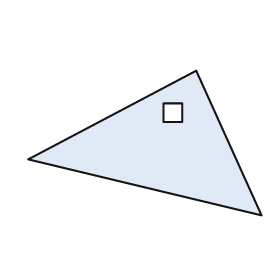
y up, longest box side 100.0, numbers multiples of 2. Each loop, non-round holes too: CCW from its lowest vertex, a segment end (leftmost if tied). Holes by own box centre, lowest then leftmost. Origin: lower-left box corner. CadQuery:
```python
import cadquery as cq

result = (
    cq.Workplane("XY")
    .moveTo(100.0, 0.0)
    .lineTo(72.0, 62.0)
    .lineTo(0.0, 24.0)
    .close()
    .moveTo(58.0, 40.0)
    .lineTo(66.0, 40.0)
    .lineTo(66.0, 48.0)
    .lineTo(58.0, 48.0)
    .close()
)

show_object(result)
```